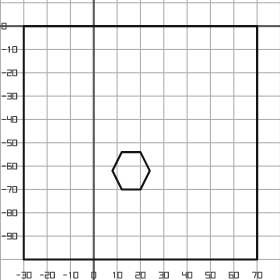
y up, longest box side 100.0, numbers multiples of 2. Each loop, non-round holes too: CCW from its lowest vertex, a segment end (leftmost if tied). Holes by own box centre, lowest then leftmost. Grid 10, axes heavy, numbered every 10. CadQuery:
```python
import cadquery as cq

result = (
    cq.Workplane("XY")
    .moveTo(-30.0, -100.0)
    .lineTo(70.0, -100.0)
    .lineTo(70.0, 0.0)
    .lineTo(-30.0, 0.0)
    .close()
    .moveTo(12.0, -70.0)
    .lineTo(20.0, -70.0)
    .lineTo(24.0, -62.0)
    .lineTo(20.0, -54.0)
    .lineTo(12.0, -54.0)
    .lineTo(8.0, -62.0)
    .close()
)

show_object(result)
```